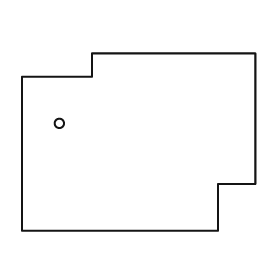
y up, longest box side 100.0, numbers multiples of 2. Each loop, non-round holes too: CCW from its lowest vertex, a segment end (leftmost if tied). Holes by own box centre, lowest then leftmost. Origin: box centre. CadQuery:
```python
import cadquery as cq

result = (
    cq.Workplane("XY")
    .moveTo(-50.0, -38.0)
    .lineTo(34.0, -38.0)
    .lineTo(34.0, -18.0)
    .lineTo(50.0, -18.0)
    .lineTo(50.0, 38.0)
    .lineTo(-20.0, 38.0)
    .lineTo(-20.0, 28.0)
    .lineTo(-50.0, 28.0)
    .close()
    .moveTo(-34.0, 8.0)
    .circle(2.0)
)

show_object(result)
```